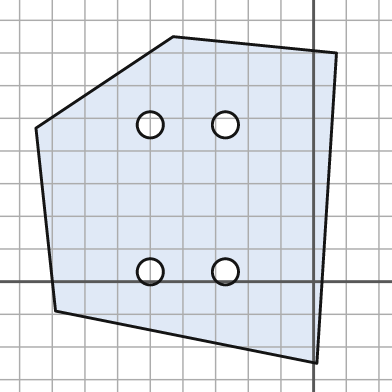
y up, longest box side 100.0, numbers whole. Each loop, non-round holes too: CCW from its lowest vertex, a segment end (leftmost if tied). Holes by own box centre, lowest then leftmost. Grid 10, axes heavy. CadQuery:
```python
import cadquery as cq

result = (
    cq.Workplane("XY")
    .moveTo(1.0, -25.0)
    .lineTo(7.0, 70.0)
    .lineTo(-43.0, 75.0)
    .lineTo(-85.0, 47.0)
    .lineTo(-79.0, -9.0)
    .close()
    .moveTo(-50.0, 3.0)
    .circle(4.0)
    .moveTo(-27.0, 3.0)
    .circle(4.0)
    .moveTo(-50.0, 48.0)
    .circle(4.0)
    .moveTo(-27.0, 48.0)
    .circle(4.0)
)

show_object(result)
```